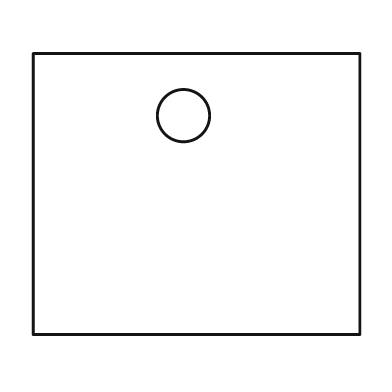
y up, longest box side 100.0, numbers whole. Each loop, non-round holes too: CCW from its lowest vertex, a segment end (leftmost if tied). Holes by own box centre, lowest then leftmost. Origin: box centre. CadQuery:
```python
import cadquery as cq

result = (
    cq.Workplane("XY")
    .moveTo(-50.0, -43.0)
    .lineTo(50.0, -43.0)
    .lineTo(50.0, 43.0)
    .lineTo(-50.0, 43.0)
    .close()
    .moveTo(-4.0, 24.0)
    .circle(8.0)
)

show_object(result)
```